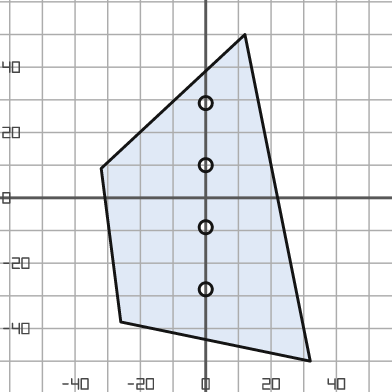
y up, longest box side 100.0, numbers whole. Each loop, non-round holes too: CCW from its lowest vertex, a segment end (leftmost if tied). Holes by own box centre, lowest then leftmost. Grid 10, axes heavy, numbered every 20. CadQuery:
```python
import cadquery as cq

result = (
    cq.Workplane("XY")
    .moveTo(32.0, -50.0)
    .lineTo(12.0, 50.0)
    .lineTo(-32.0, 9.0)
    .lineTo(-26.0, -38.0)
    .close()
    .moveTo(0.0, -28.0)
    .circle(2.0)
    .moveTo(0.0, -9.0)
    .circle(2.0)
    .moveTo(0.0, 10.0)
    .circle(2.0)
    .moveTo(0.0, 29.0)
    .circle(2.0)
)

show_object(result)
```